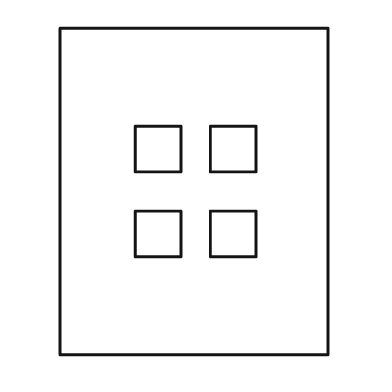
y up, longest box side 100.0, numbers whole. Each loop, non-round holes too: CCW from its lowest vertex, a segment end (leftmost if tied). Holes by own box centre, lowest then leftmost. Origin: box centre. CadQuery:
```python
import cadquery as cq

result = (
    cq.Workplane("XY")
    .moveTo(-41.0, -50.0)
    .lineTo(41.0, -50.0)
    .lineTo(41.0, 50.0)
    .lineTo(-41.0, 50.0)
    .close()
    .moveTo(-18.0, -20.0)
    .lineTo(-4.0, -20.0)
    .lineTo(-4.0, -6.0)
    .lineTo(-18.0, -6.0)
    .close()
    .moveTo(5.0, -20.0)
    .lineTo(19.0, -20.0)
    .lineTo(19.0, -6.0)
    .lineTo(5.0, -6.0)
    .close()
    .moveTo(-18.0, 6.0)
    .lineTo(-4.0, 6.0)
    .lineTo(-4.0, 20.0)
    .lineTo(-18.0, 20.0)
    .close()
    .moveTo(5.0, 6.0)
    .lineTo(19.0, 6.0)
    .lineTo(19.0, 20.0)
    .lineTo(5.0, 20.0)
    .close()
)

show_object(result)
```